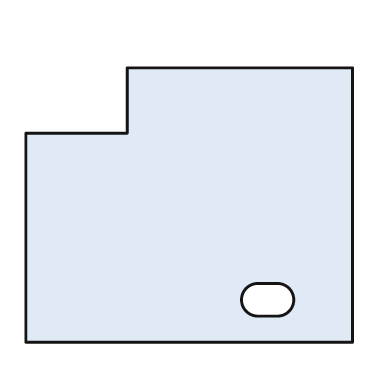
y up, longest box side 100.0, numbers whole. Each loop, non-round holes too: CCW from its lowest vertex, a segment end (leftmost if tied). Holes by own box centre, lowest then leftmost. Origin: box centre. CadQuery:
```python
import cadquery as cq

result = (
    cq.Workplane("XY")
    .moveTo(-50.0, -42.0)
    .lineTo(50.0, -42.0)
    .lineTo(50.0, 42.0)
    .lineTo(-19.0, 42.0)
    .lineTo(-19.0, 22.0)
    .lineTo(-50.0, 22.0)
    .close()
    .moveTo(21.0, -34.0)
    .lineTo(27.0, -34.0)
    .threePointArc((32.0, -29.0), (27.0, -24.0))
    .lineTo(21.0, -24.0)
    .threePointArc((16.0, -29.0), (21.0, -34.0))
    .close()
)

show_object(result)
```